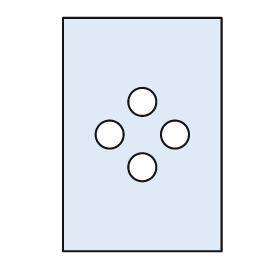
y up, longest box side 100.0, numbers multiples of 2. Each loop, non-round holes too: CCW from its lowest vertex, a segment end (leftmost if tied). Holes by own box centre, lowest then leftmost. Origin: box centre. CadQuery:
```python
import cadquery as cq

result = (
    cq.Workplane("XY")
    .moveTo(-34.0, -50.0)
    .lineTo(34.0, -50.0)
    .lineTo(34.0, 50.0)
    .lineTo(-34.0, 50.0)
    .close()
    .moveTo(0.0, -14.0)
    .circle(6.0)
    .moveTo(-14.0, 0.0)
    .circle(6.0)
    .moveTo(14.0, 0.0)
    .circle(6.0)
    .moveTo(0.0, 14.0)
    .circle(6.0)
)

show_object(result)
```